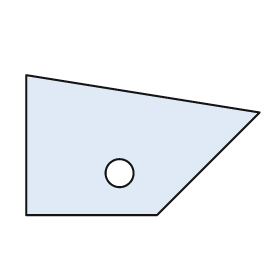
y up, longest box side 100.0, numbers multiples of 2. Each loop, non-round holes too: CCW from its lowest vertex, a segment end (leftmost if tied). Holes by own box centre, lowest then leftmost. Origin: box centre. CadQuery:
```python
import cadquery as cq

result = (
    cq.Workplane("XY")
    .moveTo(-50.0, -30.0)
    .lineTo(6.0, -30.0)
    .lineTo(50.0, 14.0)
    .lineTo(-50.0, 30.0)
    .close()
    .moveTo(-10.0, -12.0)
    .circle(6.0)
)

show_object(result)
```